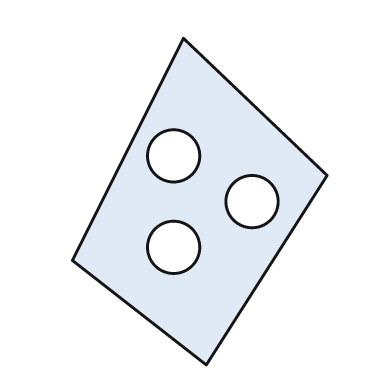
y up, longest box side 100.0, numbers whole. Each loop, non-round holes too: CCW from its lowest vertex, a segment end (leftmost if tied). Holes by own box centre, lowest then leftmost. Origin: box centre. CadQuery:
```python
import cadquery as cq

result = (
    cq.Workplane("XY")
    .moveTo(2.0, -50.0)
    .lineTo(39.0, 8.0)
    .lineTo(-5.0, 50.0)
    .lineTo(-39.0, -18.0)
    .close()
    .moveTo(-8.0, -14.0)
    .circle(8.0)
    .moveTo(16.0, 0.0)
    .circle(8.0)
    .moveTo(-8.0, 14.0)
    .circle(8.0)
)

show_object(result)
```